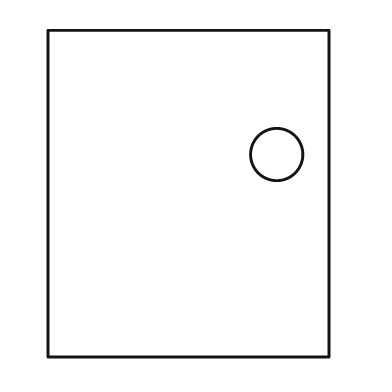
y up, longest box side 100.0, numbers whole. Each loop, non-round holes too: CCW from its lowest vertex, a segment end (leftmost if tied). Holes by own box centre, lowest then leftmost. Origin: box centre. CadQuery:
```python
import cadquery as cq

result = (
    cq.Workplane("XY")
    .moveTo(-43.0, -50.0)
    .lineTo(43.0, -50.0)
    .lineTo(43.0, 50.0)
    .lineTo(-43.0, 50.0)
    .close()
    .moveTo(27.0, 12.0)
    .circle(8.0)
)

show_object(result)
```